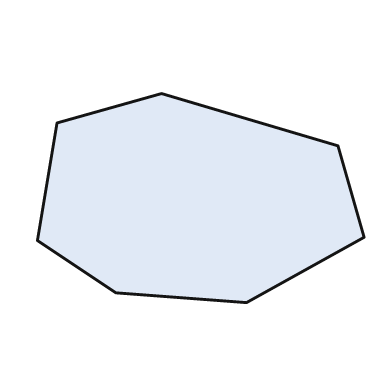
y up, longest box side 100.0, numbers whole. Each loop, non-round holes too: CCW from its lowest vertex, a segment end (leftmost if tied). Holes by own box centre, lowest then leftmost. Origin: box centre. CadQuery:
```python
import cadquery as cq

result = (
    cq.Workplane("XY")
    .moveTo(14.0, -32.0)
    .lineTo(50.0, -12.0)
    .lineTo(42.0, 16.0)
    .lineTo(-12.0, 32.0)
    .lineTo(-44.0, 23.0)
    .lineTo(-50.0, -13.0)
    .lineTo(-26.0, -29.0)
    .close()
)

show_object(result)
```